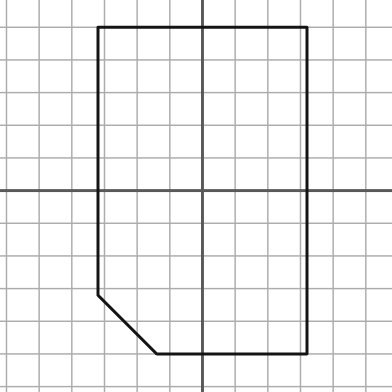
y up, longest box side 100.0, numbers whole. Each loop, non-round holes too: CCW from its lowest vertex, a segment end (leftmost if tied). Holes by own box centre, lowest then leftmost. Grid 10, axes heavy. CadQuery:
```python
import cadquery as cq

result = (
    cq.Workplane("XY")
    .moveTo(-14.0, -50.0)
    .lineTo(32.0, -50.0)
    .lineTo(32.0, 50.0)
    .lineTo(-32.0, 50.0)
    .lineTo(-32.0, -32.0)
    .close()
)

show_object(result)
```